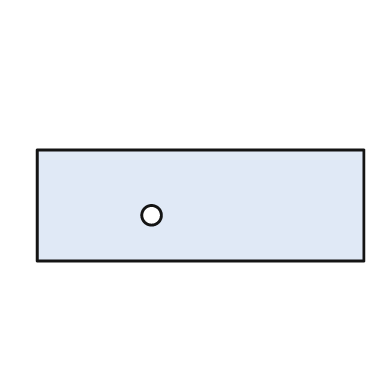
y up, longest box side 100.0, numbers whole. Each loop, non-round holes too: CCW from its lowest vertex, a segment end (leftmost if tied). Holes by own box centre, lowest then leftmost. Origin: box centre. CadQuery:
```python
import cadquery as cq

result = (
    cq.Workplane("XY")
    .moveTo(-50.0, -17.0)
    .lineTo(50.0, -17.0)
    .lineTo(50.0, 17.0)
    .lineTo(-50.0, 17.0)
    .close()
    .moveTo(-15.0, -3.0)
    .circle(3.0)
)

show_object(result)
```